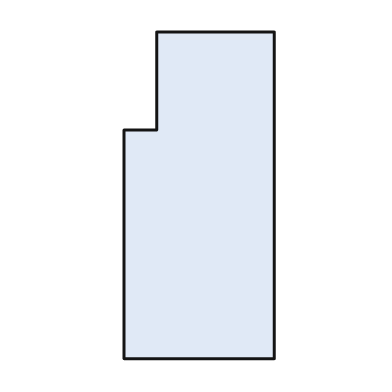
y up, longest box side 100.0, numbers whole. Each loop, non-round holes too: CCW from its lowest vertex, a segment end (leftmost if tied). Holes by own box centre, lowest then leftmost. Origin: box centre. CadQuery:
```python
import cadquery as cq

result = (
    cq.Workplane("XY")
    .moveTo(-23.0, -50.0)
    .lineTo(23.0, -50.0)
    .lineTo(23.0, 50.0)
    .lineTo(-13.0, 50.0)
    .lineTo(-13.0, 20.0)
    .lineTo(-23.0, 20.0)
    .close()
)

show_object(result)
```